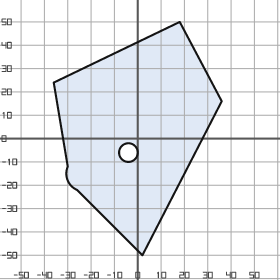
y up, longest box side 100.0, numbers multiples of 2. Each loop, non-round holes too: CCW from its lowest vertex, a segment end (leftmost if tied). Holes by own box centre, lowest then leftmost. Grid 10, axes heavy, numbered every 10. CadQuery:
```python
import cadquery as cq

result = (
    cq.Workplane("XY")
    .moveTo(2.0, -50.0)
    .lineTo(36.0, 16.0)
    .lineTo(18.0, 50.0)
    .lineTo(-36.0, 24.0)
    .lineTo(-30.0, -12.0)
    .threePointArc((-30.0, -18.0), (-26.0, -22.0))
    .close()
    .moveTo(-4.0, -6.0)
    .circle(4.0)
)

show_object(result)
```